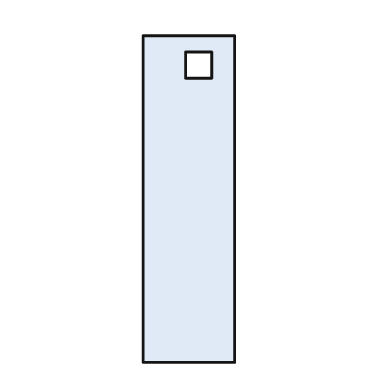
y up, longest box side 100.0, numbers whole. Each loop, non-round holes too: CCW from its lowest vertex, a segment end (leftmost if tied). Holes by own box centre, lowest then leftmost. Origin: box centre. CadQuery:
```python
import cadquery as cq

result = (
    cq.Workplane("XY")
    .moveTo(-14.0, -50.0)
    .lineTo(14.0, -50.0)
    .lineTo(14.0, 50.0)
    .lineTo(-14.0, 50.0)
    .close()
    .moveTo(-1.0, 37.0)
    .lineTo(7.0, 37.0)
    .lineTo(7.0, 45.0)
    .lineTo(-1.0, 45.0)
    .close()
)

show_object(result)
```